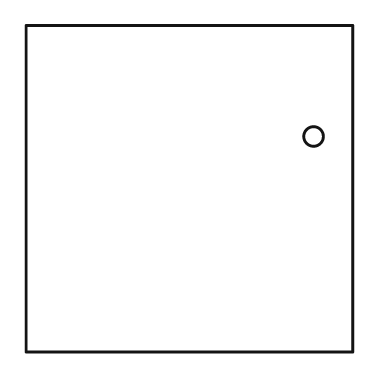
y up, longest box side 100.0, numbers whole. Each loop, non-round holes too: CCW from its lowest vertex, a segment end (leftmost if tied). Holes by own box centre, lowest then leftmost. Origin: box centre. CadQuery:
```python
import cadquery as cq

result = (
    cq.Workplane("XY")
    .moveTo(-50.0, -50.0)
    .lineTo(50.0, -50.0)
    .lineTo(50.0, 50.0)
    .lineTo(-50.0, 50.0)
    .close()
    .moveTo(38.0, 16.0)
    .circle(3.0)
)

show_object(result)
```